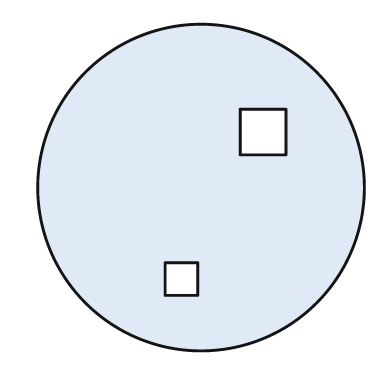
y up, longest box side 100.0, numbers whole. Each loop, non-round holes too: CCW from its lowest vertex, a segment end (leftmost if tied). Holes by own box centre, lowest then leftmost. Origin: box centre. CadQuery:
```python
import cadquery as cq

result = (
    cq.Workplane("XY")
    .moveTo(0.0, 0.0)
    .circle(50.0)
    .moveTo(-11.0, -33.0)
    .lineTo(-1.0, -33.0)
    .lineTo(-1.0, -23.0)
    .lineTo(-11.0, -23.0)
    .close()
    .moveTo(12.0, 10.0)
    .lineTo(26.0, 10.0)
    .lineTo(26.0, 24.0)
    .lineTo(12.0, 24.0)
    .close()
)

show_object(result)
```